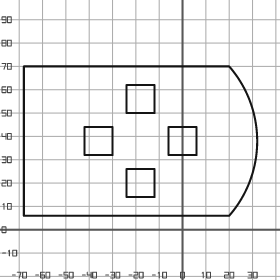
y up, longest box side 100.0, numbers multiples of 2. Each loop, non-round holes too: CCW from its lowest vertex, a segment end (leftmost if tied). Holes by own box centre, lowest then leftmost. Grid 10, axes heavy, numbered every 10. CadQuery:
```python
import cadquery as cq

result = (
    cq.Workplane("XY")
    .moveTo(-68.0, 6.0)
    .lineTo(20.0, 6.0)
    .threePointArc((32.0, 38.0), (20.0, 70.0))
    .lineTo(-68.0, 70.0)
    .close()
    .moveTo(-24.0, 14.0)
    .lineTo(-12.0, 14.0)
    .lineTo(-12.0, 26.0)
    .lineTo(-24.0, 26.0)
    .close()
    .moveTo(-42.0, 32.0)
    .lineTo(-30.0, 32.0)
    .lineTo(-30.0, 44.0)
    .lineTo(-42.0, 44.0)
    .close()
    .moveTo(-6.0, 32.0)
    .lineTo(6.0, 32.0)
    .lineTo(6.0, 44.0)
    .lineTo(-6.0, 44.0)
    .close()
    .moveTo(-24.0, 50.0)
    .lineTo(-12.0, 50.0)
    .lineTo(-12.0, 62.0)
    .lineTo(-24.0, 62.0)
    .close()
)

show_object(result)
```